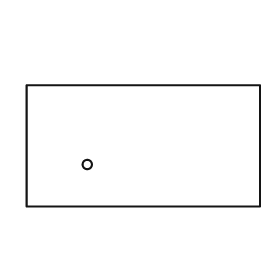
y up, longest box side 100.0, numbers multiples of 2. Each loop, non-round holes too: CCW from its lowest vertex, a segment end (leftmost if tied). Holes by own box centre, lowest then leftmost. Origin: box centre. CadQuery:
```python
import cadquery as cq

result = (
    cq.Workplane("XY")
    .moveTo(-50.0, -26.0)
    .lineTo(50.0, -26.0)
    .lineTo(50.0, 26.0)
    .lineTo(-50.0, 26.0)
    .close()
    .moveTo(-24.0, -8.0)
    .circle(2.0)
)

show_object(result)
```